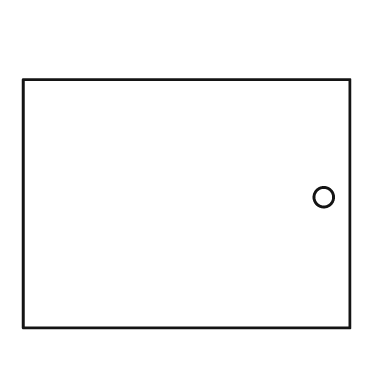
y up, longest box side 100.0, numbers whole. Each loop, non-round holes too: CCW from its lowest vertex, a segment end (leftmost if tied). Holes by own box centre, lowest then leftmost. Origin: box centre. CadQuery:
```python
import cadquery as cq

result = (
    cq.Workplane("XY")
    .moveTo(-50.0, -38.0)
    .lineTo(50.0, -38.0)
    .lineTo(50.0, 38.0)
    .lineTo(-50.0, 38.0)
    .close()
    .moveTo(42.0, 2.0)
    .circle(3.0)
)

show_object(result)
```